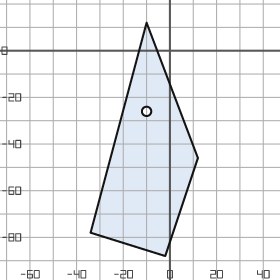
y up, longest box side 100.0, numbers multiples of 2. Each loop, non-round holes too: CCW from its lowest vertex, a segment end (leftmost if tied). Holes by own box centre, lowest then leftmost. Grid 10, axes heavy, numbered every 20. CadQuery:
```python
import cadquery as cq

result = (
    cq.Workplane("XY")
    .moveTo(-2.0, -88.0)
    .lineTo(12.0, -46.0)
    .lineTo(-10.0, 12.0)
    .lineTo(-34.0, -78.0)
    .close()
    .moveTo(-10.0, -26.0)
    .circle(2.0)
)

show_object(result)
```